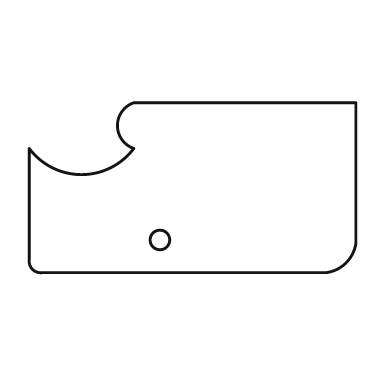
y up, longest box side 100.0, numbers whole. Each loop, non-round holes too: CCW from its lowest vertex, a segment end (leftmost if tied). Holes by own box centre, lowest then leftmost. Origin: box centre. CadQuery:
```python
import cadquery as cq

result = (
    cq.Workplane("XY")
    .moveTo(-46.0, -26.0)
    .lineTo(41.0, -26.0)
    .threePointArc((47.0, -23.0), (50.0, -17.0))
    .lineTo(50.0, 26.0)
    .lineTo(-18.0, 26.0)
    .threePointArc((-23.0, 19.0), (-18.0, 12.0))
    .threePointArc((-34.0, 4.0), (-50.0, 12.0))
    .lineTo(-50.0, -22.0)
    .threePointArc((-49.0, -25.0), (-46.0, -26.0))
    .close()
    .moveTo(-10.0, -16.0)
    .circle(3.0)
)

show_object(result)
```